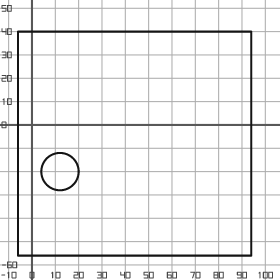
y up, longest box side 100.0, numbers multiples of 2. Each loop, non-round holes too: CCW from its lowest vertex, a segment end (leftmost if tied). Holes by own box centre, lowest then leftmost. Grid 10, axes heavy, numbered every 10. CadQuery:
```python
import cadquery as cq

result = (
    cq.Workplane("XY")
    .moveTo(-6.0, -56.0)
    .lineTo(94.0, -56.0)
    .lineTo(94.0, 40.0)
    .lineTo(-6.0, 40.0)
    .close()
    .moveTo(12.0, -20.0)
    .circle(8.0)
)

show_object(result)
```